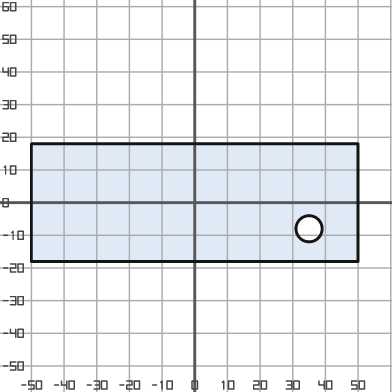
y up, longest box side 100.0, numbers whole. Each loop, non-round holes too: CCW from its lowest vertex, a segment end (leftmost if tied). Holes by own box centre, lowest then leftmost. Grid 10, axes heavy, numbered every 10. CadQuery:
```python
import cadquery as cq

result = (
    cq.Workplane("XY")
    .moveTo(-50.0, -18.0)
    .lineTo(50.0, -18.0)
    .lineTo(50.0, 18.0)
    .lineTo(-50.0, 18.0)
    .close()
    .moveTo(35.0, -8.0)
    .circle(4.0)
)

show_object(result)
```